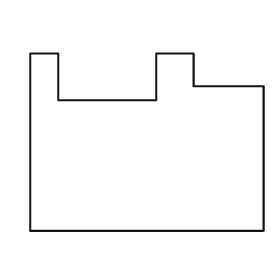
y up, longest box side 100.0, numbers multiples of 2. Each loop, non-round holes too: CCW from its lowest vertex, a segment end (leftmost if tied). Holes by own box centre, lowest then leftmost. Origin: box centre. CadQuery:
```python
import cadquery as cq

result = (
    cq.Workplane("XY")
    .moveTo(-50.0, -38.0)
    .lineTo(50.0, -38.0)
    .lineTo(50.0, 24.0)
    .lineTo(20.0, 24.0)
    .lineTo(20.0, 38.0)
    .lineTo(4.0, 38.0)
    .lineTo(4.0, 18.0)
    .lineTo(-38.0, 18.0)
    .lineTo(-38.0, 38.0)
    .lineTo(-50.0, 38.0)
    .close()
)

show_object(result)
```